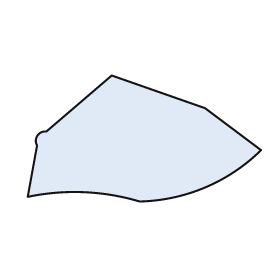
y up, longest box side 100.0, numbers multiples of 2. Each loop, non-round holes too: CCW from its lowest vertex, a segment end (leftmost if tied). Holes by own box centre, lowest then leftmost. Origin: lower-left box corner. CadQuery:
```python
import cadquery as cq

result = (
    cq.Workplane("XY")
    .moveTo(48.0, 0.0)
    .threePointArc((76.0, 6.0), (100.0, 22.0))
    .lineTo(76.0, 40.0)
    .lineTo(36.0, 54.0)
    .lineTo(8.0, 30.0)
    .threePointArc((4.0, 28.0), (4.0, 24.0))
    .lineTo(0.0, 2.0)
    .threePointArc((24.0, 4.0), (48.0, 0.0))
    .close()
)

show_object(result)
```